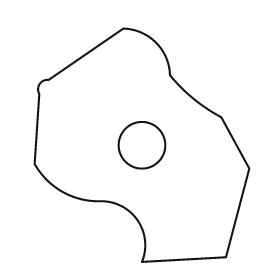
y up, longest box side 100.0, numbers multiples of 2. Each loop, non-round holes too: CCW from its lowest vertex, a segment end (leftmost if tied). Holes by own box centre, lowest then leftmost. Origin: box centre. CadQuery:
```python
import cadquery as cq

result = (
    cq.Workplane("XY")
    .moveTo(0.0, -50.0)
    .lineTo(36.0, -48.0)
    .lineTo(46.0, -10.0)
    .lineTo(34.0, 12.0)
    .threePointArc((22.0, 20.0), (12.0, 30.0))
    .threePointArc((6.0, 44.0), (-8.0, 50.0))
    .lineTo(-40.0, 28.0)
    .threePointArc((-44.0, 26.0), (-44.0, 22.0))
    .lineTo(-46.0, -8.0)
    .threePointArc((-34.0, -20.0), (-18.0, -24.0))
    .threePointArc((-2.0, -32.0), (0.0, -50.0))
    .close()
    .moveTo(0.0, 0.0)
    .circle(10.0)
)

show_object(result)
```